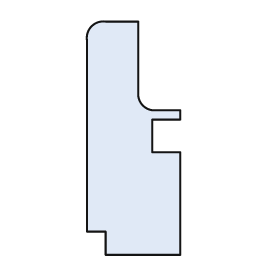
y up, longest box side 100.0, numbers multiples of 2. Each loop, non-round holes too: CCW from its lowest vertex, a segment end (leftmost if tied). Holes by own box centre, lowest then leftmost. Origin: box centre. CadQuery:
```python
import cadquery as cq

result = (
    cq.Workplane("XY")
    .moveTo(-12.0, -50.0)
    .lineTo(20.0, -50.0)
    .lineTo(20.0, -6.0)
    .lineTo(8.0, -6.0)
    .lineTo(8.0, 8.0)
    .lineTo(20.0, 8.0)
    .lineTo(20.0, 12.0)
    .lineTo(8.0, 12.0)
    .threePointArc((4.0, 14.0), (2.0, 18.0))
    .lineTo(2.0, 50.0)
    .lineTo(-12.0, 50.0)
    .threePointArc((-18.0, 48.0), (-20.0, 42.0))
    .lineTo(-20.0, -40.0)
    .lineTo(-12.0, -40.0)
    .close()
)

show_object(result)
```